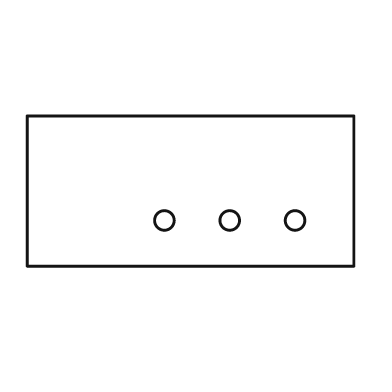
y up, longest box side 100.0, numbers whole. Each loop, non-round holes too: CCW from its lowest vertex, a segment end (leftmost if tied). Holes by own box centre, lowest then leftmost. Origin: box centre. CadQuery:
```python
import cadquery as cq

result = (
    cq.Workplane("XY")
    .moveTo(-50.0, -23.0)
    .lineTo(50.0, -23.0)
    .lineTo(50.0, 23.0)
    .lineTo(-50.0, 23.0)
    .close()
    .moveTo(-8.0, -9.0)
    .circle(3.0)
    .moveTo(12.0, -9.0)
    .circle(3.0)
    .moveTo(32.0, -9.0)
    .circle(3.0)
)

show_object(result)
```